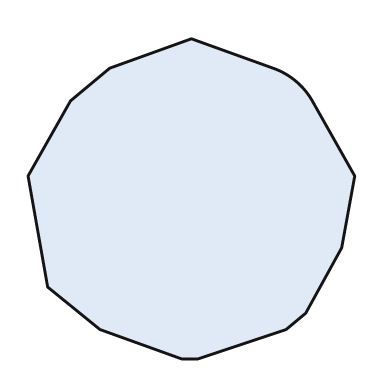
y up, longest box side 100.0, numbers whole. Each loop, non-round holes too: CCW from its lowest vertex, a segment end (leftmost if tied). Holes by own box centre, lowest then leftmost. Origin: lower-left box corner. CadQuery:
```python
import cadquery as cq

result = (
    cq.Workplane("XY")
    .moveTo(47.0, 0.0)
    .lineTo(52.0, 0.0)
    .lineTo(79.0, 9.0)
    .lineTo(85.0, 14.0)
    .lineTo(96.0, 34.0)
    .lineTo(100.0, 56.0)
    .lineTo(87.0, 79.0)
    .threePointArc((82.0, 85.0), (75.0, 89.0))
    .lineTo(50.0, 98.0)
    .lineTo(25.0, 89.0)
    .lineTo(13.0, 79.0)
    .lineTo(0.0, 56.0)
    .lineTo(6.0, 22.0)
    .lineTo(22.0, 9.0)
    .close()
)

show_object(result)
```